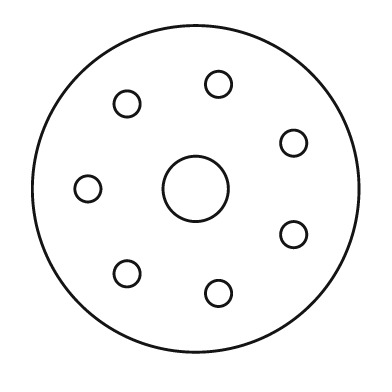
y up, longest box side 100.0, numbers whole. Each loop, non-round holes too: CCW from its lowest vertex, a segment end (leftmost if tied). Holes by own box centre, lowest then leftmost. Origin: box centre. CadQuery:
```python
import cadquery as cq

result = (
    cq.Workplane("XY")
    .moveTo(0.0, 0.0)
    .circle(50.0)
    .moveTo(7.0, -32.0)
    .circle(4.0)
    .moveTo(-21.0, -26.0)
    .circle(4.0)
    .moveTo(30.0, -14.0)
    .circle(4.0)
    .moveTo(-33.0, 0.0)
    .circle(4.0)
    .moveTo(0.0, 0.0)
    .circle(10.0)
    .moveTo(30.0, 14.0)
    .circle(4.0)
    .moveTo(-21.0, 26.0)
    .circle(4.0)
    .moveTo(7.0, 32.0)
    .circle(4.0)
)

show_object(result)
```